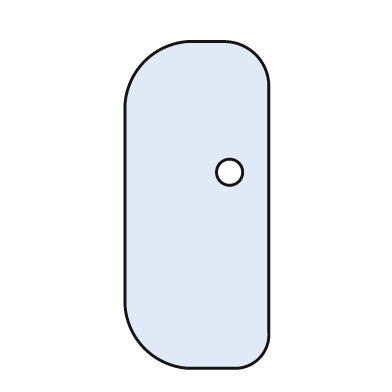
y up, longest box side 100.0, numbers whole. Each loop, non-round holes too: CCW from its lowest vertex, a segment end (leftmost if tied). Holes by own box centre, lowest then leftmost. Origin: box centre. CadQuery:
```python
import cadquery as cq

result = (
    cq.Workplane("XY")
    .moveTo(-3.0, -50.0)
    .lineTo(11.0, -50.0)
    .threePointArc((19.0, -47.0), (22.0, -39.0))
    .lineTo(22.0, 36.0)
    .threePointArc((18.0, 46.0), (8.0, 50.0))
    .lineTo(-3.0, 50.0)
    .threePointArc((-16.0, 44.0), (-22.0, 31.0))
    .lineTo(-22.0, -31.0)
    .threePointArc((-16.0, -44.0), (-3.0, -50.0))
    .close()
    .moveTo(10.0, 10.0)
    .circle(4.0)
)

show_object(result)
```